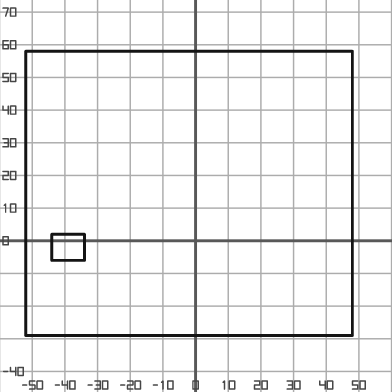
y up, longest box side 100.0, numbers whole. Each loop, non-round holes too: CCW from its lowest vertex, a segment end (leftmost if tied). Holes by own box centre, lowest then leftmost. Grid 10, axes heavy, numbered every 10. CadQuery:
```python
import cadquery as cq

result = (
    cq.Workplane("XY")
    .moveTo(-52.0, -29.0)
    .lineTo(48.0, -29.0)
    .lineTo(48.0, 58.0)
    .lineTo(-52.0, 58.0)
    .close()
    .moveTo(-44.0, -6.0)
    .lineTo(-34.0, -6.0)
    .lineTo(-34.0, 2.0)
    .lineTo(-44.0, 2.0)
    .close()
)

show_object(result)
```